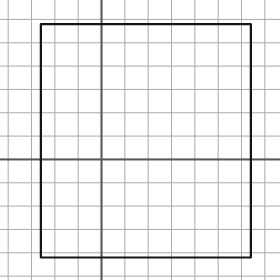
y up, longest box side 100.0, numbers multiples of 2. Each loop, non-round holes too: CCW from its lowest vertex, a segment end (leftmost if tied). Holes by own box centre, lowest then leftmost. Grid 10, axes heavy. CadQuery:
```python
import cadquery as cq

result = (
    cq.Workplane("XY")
    .moveTo(-26.0, -42.0)
    .lineTo(64.0, -42.0)
    .lineTo(64.0, 58.0)
    .lineTo(-26.0, 58.0)
    .close()
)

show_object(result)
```